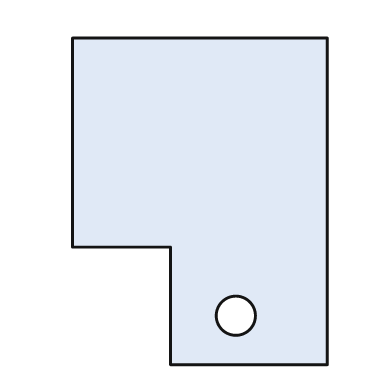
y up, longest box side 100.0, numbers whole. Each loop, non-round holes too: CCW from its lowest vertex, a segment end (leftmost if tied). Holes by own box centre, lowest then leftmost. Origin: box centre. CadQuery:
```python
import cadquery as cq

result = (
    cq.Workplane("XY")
    .moveTo(-9.0, -50.0)
    .lineTo(39.0, -50.0)
    .lineTo(39.0, 50.0)
    .lineTo(-39.0, 50.0)
    .lineTo(-39.0, -14.0)
    .lineTo(-9.0, -14.0)
    .close()
    .moveTo(11.0, -35.0)
    .circle(6.0)
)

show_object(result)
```